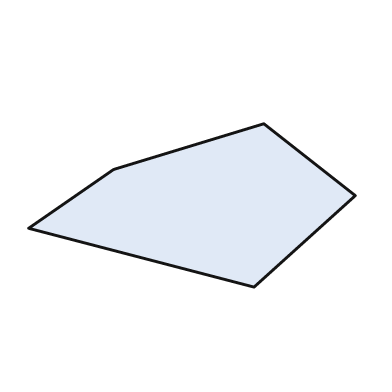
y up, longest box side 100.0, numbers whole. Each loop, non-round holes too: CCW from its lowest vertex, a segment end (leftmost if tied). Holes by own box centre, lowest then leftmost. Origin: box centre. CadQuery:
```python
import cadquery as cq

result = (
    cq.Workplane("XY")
    .moveTo(19.0, -25.0)
    .lineTo(50.0, 3.0)
    .lineTo(22.0, 25.0)
    .lineTo(-24.0, 11.0)
    .lineTo(-50.0, -7.0)
    .close()
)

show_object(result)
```